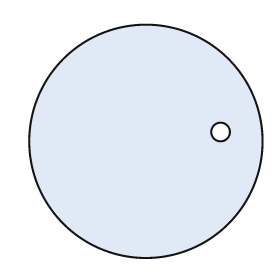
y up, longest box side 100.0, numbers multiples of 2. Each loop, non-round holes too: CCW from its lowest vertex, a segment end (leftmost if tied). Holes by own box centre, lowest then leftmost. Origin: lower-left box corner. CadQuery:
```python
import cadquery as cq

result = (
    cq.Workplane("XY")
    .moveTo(50.0, 50.0)
    .circle(50.0)
    .moveTo(82.0, 54.0)
    .circle(4.0)
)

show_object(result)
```